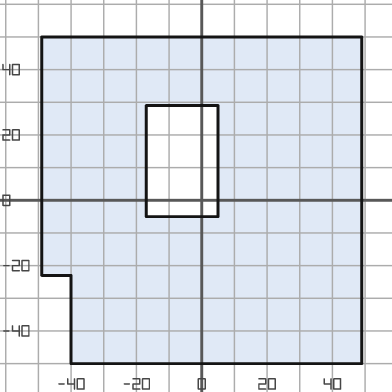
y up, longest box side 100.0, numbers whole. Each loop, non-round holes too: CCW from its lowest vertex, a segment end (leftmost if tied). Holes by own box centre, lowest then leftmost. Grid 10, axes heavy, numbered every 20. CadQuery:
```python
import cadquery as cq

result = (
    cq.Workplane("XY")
    .moveTo(-40.0, -50.0)
    .lineTo(49.0, -50.0)
    .lineTo(49.0, 50.0)
    .lineTo(-49.0, 50.0)
    .lineTo(-49.0, -23.0)
    .lineTo(-40.0, -23.0)
    .close()
    .moveTo(-17.0, -5.0)
    .lineTo(5.0, -5.0)
    .lineTo(5.0, 29.0)
    .lineTo(-17.0, 29.0)
    .close()
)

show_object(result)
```